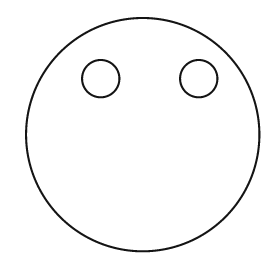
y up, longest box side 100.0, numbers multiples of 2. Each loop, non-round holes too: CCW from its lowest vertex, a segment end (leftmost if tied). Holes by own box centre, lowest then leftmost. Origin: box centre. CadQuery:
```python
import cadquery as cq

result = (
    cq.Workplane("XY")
    .moveTo(0.0, 0.0)
    .circle(50.0)
    .moveTo(-18.0, 24.0)
    .circle(8.0)
    .moveTo(24.0, 24.0)
    .circle(8.0)
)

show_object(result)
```